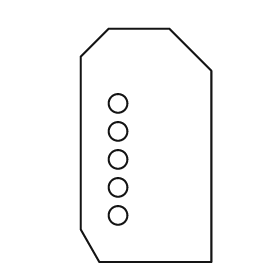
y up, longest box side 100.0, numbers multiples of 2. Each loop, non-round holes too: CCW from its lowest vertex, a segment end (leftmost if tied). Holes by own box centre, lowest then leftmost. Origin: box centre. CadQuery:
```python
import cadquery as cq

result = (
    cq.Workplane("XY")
    .moveTo(-20.0, -50.0)
    .lineTo(28.0, -50.0)
    .lineTo(28.0, 32.0)
    .lineTo(10.0, 50.0)
    .lineTo(-16.0, 50.0)
    .lineTo(-28.0, 38.0)
    .lineTo(-28.0, -36.0)
    .close()
    .moveTo(-12.0, -30.0)
    .circle(4.0)
    .moveTo(-12.0, -18.0)
    .circle(4.0)
    .moveTo(-12.0, -6.0)
    .circle(4.0)
    .moveTo(-12.0, 6.0)
    .circle(4.0)
    .moveTo(-12.0, 18.0)
    .circle(4.0)
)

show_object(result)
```